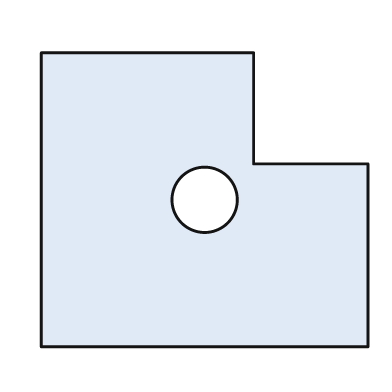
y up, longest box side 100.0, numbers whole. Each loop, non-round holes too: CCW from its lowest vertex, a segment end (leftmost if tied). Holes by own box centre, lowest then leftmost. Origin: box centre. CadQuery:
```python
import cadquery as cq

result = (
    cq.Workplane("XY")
    .moveTo(-50.0, -45.0)
    .lineTo(50.0, -45.0)
    .lineTo(50.0, 11.0)
    .lineTo(15.0, 11.0)
    .lineTo(15.0, 45.0)
    .lineTo(-50.0, 45.0)
    .close()
    .moveTo(0.0, 0.0)
    .circle(10.0)
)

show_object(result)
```